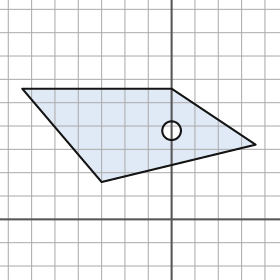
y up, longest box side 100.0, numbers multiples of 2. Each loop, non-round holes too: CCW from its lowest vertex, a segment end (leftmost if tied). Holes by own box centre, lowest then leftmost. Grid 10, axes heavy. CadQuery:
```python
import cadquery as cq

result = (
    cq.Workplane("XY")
    .moveTo(-30.0, 16.0)
    .lineTo(36.0, 32.0)
    .lineTo(0.0, 56.0)
    .lineTo(-64.0, 56.0)
    .close()
    .moveTo(0.0, 38.0)
    .circle(4.0)
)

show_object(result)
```